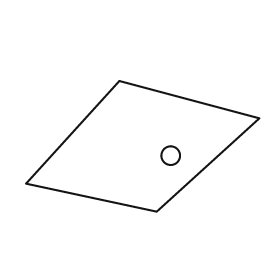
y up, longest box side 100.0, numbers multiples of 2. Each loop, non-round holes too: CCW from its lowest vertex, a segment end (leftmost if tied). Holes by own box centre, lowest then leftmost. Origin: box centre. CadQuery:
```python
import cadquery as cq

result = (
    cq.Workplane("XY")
    .moveTo(6.0, -28.0)
    .lineTo(50.0, 12.0)
    .lineTo(-10.0, 28.0)
    .lineTo(-50.0, -16.0)
    .close()
    .moveTo(12.0, -4.0)
    .circle(4.0)
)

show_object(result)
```